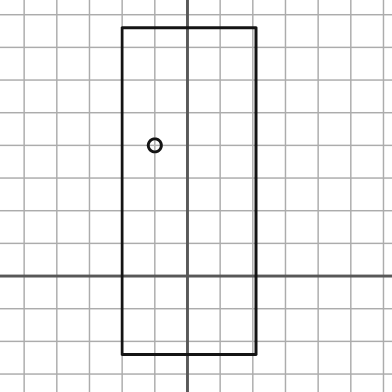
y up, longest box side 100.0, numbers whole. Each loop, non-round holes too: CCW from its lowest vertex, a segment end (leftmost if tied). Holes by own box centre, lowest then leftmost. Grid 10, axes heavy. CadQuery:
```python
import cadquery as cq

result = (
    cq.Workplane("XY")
    .moveTo(-20.0, -24.0)
    .lineTo(21.0, -24.0)
    .lineTo(21.0, 76.0)
    .lineTo(-20.0, 76.0)
    .close()
    .moveTo(-10.0, 40.0)
    .circle(2.0)
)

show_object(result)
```